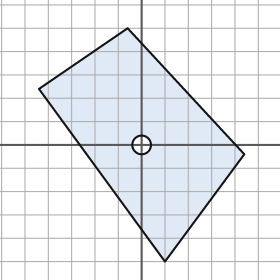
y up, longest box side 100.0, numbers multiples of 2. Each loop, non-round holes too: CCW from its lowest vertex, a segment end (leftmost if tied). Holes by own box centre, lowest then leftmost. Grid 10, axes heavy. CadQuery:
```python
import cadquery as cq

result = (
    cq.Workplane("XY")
    .moveTo(10.0, -50.0)
    .lineTo(44.0, -4.0)
    .lineTo(-6.0, 50.0)
    .lineTo(-44.0, 24.0)
    .close()
    .moveTo(0.0, 0.0)
    .circle(4.0)
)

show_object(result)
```